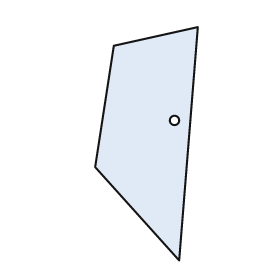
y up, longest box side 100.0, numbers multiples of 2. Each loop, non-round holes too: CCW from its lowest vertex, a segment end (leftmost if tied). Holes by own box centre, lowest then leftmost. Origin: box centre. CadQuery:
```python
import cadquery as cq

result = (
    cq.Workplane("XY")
    .moveTo(14.0, -50.0)
    .lineTo(22.0, 50.0)
    .lineTo(-14.0, 42.0)
    .lineTo(-22.0, -10.0)
    .close()
    .moveTo(12.0, 10.0)
    .circle(2.0)
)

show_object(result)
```